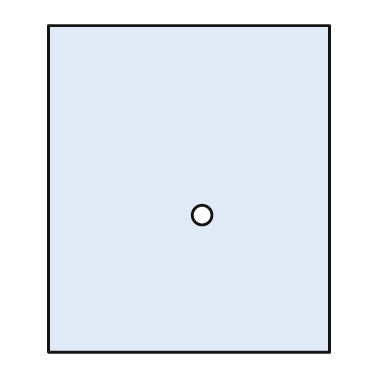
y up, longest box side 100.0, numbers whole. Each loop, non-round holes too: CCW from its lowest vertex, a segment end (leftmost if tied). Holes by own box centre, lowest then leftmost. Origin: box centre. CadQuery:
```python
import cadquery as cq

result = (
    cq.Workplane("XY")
    .moveTo(-43.0, -50.0)
    .lineTo(43.0, -50.0)
    .lineTo(43.0, 50.0)
    .lineTo(-43.0, 50.0)
    .close()
    .moveTo(4.0, -8.0)
    .circle(3.0)
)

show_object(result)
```